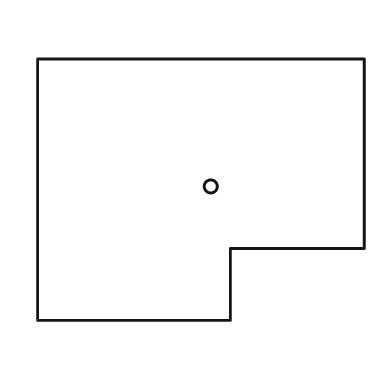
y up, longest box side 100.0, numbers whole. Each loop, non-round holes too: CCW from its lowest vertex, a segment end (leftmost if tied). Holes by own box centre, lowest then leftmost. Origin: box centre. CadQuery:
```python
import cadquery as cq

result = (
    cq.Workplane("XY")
    .moveTo(-50.0, -40.0)
    .lineTo(9.0, -40.0)
    .lineTo(9.0, -18.0)
    .lineTo(50.0, -18.0)
    .lineTo(50.0, 40.0)
    .lineTo(-50.0, 40.0)
    .close()
    .moveTo(3.0, 1.0)
    .circle(2.0)
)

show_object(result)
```